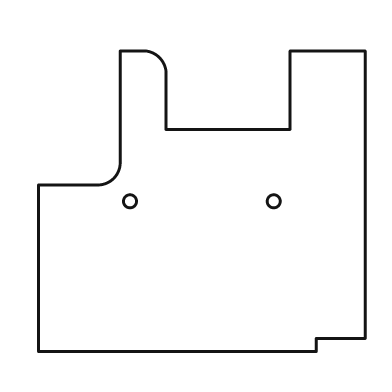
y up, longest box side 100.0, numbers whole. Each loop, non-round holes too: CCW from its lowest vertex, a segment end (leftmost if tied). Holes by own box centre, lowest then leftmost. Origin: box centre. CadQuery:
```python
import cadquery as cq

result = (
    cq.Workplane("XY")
    .moveTo(-50.0, -46.0)
    .lineTo(35.0, -46.0)
    .lineTo(35.0, -42.0)
    .lineTo(50.0, -42.0)
    .lineTo(50.0, 46.0)
    .lineTo(27.0, 46.0)
    .lineTo(27.0, 22.0)
    .lineTo(-11.0, 22.0)
    .lineTo(-11.0, 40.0)
    .threePointArc((-13.0, 44.0), (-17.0, 46.0))
    .lineTo(-25.0, 46.0)
    .lineTo(-25.0, 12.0)
    .threePointArc((-27.0, 7.0), (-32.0, 5.0))
    .lineTo(-50.0, 5.0)
    .close()
    .moveTo(-22.0, 0.0)
    .circle(2.0)
    .moveTo(22.0, 0.0)
    .circle(2.0)
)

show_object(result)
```